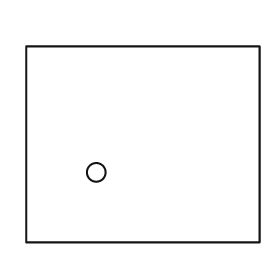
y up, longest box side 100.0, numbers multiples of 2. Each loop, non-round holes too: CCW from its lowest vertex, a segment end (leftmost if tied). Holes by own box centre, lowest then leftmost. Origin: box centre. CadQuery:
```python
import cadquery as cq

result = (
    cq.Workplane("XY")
    .moveTo(-50.0, -42.0)
    .lineTo(50.0, -42.0)
    .lineTo(50.0, 42.0)
    .lineTo(-50.0, 42.0)
    .close()
    .moveTo(-20.0, -12.0)
    .circle(4.0)
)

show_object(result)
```